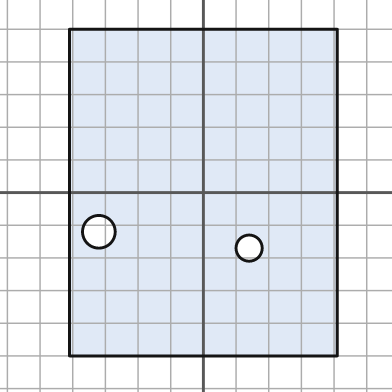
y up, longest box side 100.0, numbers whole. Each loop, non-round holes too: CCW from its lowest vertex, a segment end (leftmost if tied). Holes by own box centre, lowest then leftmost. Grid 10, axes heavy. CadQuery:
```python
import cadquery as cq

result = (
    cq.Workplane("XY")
    .moveTo(-41.0, -50.0)
    .lineTo(41.0, -50.0)
    .lineTo(41.0, 50.0)
    .lineTo(-41.0, 50.0)
    .close()
    .moveTo(14.0, -17.0)
    .circle(4.0)
    .moveTo(-32.0, -12.0)
    .circle(5.0)
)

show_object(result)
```